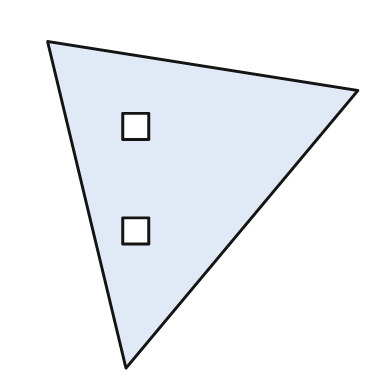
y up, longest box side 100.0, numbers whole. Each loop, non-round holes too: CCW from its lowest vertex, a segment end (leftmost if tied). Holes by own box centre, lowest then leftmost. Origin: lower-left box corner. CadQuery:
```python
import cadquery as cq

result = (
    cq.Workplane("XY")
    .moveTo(24.0, 0.0)
    .lineTo(95.0, 85.0)
    .lineTo(0.0, 100.0)
    .close()
    .moveTo(23.0, 38.0)
    .lineTo(31.0, 38.0)
    .lineTo(31.0, 46.0)
    .lineTo(23.0, 46.0)
    .close()
    .moveTo(23.0, 70.0)
    .lineTo(31.0, 70.0)
    .lineTo(31.0, 78.0)
    .lineTo(23.0, 78.0)
    .close()
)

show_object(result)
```